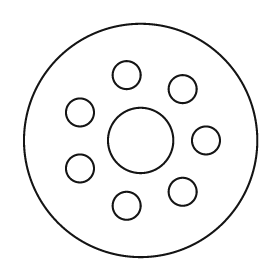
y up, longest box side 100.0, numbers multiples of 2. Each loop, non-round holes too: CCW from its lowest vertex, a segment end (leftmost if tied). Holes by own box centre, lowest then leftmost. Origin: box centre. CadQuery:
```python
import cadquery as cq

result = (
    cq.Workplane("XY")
    .moveTo(0.0, 0.0)
    .circle(50.0)
    .moveTo(-6.0, -28.0)
    .circle(6.0)
    .moveTo(18.0, -22.0)
    .circle(6.0)
    .moveTo(-26.0, -12.0)
    .circle(6.0)
    .moveTo(0.0, 0.0)
    .circle(14.0)
    .moveTo(28.0, 0.0)
    .circle(6.0)
    .moveTo(-26.0, 12.0)
    .circle(6.0)
    .moveTo(18.0, 22.0)
    .circle(6.0)
    .moveTo(-6.0, 28.0)
    .circle(6.0)
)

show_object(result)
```